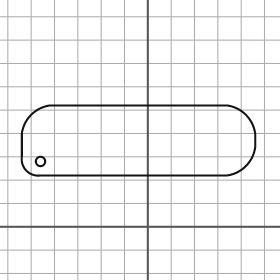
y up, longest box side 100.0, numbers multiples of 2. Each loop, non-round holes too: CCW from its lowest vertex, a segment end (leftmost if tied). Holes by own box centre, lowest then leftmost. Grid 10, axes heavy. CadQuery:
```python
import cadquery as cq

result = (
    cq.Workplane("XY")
    .moveTo(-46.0, 22.0)
    .lineTo(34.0, 22.0)
    .threePointArc((42.0, 26.0), (46.0, 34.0))
    .lineTo(46.0, 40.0)
    .threePointArc((42.0, 48.0), (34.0, 52.0))
    .lineTo(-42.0, 52.0)
    .threePointArc((-50.0, 48.0), (-54.0, 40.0))
    .lineTo(-54.0, 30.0)
    .threePointArc((-52.0, 24.0), (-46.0, 22.0))
    .close()
    .moveTo(-46.0, 28.0)
    .circle(2.0)
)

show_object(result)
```